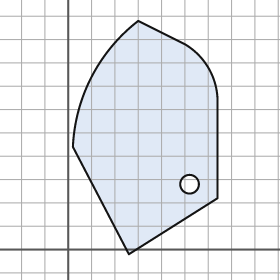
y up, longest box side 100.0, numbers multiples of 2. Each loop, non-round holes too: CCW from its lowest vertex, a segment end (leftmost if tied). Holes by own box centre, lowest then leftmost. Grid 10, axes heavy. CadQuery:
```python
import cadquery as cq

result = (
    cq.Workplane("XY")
    .moveTo(26.0, -2.0)
    .lineTo(64.0, 22.0)
    .lineTo(64.0, 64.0)
    .threePointArc((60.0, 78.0), (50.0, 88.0))
    .lineTo(30.0, 98.0)
    .threePointArc((10.0, 74.0), (2.0, 44.0))
    .close()
    .moveTo(52.0, 28.0)
    .circle(4.0)
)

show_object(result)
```